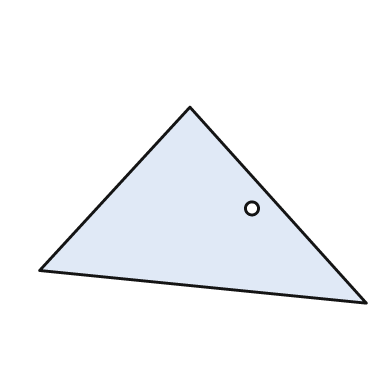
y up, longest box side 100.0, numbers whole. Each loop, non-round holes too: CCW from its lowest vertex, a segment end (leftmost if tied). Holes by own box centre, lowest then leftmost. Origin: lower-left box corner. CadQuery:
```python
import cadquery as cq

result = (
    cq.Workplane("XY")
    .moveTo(100.0, 0.0)
    .lineTo(46.0, 60.0)
    .lineTo(0.0, 10.0)
    .close()
    .moveTo(65.0, 29.0)
    .circle(2.0)
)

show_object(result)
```